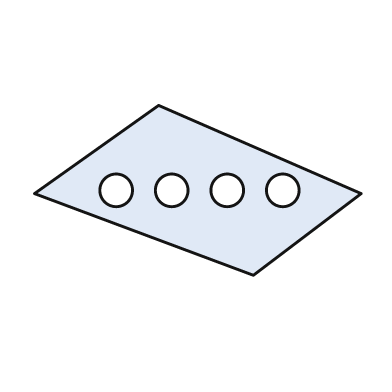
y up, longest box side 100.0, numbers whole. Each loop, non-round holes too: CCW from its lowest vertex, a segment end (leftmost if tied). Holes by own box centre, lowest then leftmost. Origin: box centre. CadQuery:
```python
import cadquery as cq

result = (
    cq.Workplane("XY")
    .moveTo(17.0, -26.0)
    .lineTo(50.0, -1.0)
    .lineTo(-12.0, 26.0)
    .lineTo(-50.0, -1.0)
    .close()
    .moveTo(-25.0, 0.0)
    .circle(5.0)
    .moveTo(-8.0, 0.0)
    .circle(5.0)
    .moveTo(9.0, 0.0)
    .circle(5.0)
    .moveTo(26.0, 0.0)
    .circle(5.0)
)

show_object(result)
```